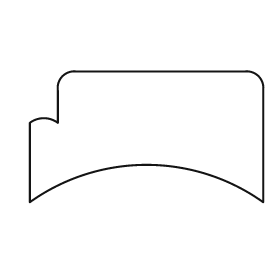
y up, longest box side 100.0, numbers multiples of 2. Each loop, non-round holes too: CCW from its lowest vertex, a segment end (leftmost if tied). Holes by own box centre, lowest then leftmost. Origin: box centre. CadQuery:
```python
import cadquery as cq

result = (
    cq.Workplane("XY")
    .moveTo(-50.0, -28.0)
    .threePointArc((0.0, -12.0), (50.0, -28.0))
    .lineTo(50.0, 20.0)
    .threePointArc((48.0, 26.0), (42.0, 28.0))
    .lineTo(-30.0, 28.0)
    .threePointArc((-36.0, 26.0), (-38.0, 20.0))
    .lineTo(-38.0, 6.0)
    .threePointArc((-44.0, 8.0), (-50.0, 6.0))
    .close()
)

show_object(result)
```